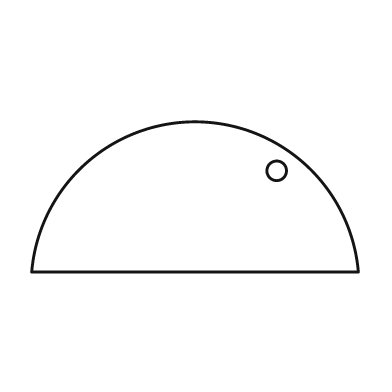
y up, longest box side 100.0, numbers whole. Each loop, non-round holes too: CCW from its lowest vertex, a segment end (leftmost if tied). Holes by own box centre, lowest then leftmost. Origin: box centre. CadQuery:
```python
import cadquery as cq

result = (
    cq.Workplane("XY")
    .moveTo(-50.0, -23.0)
    .lineTo(50.0, -23.0)
    .threePointArc((0.0, 23.0), (-50.0, -23.0))
    .close()
    .moveTo(25.0, 8.0)
    .circle(3.0)
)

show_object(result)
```